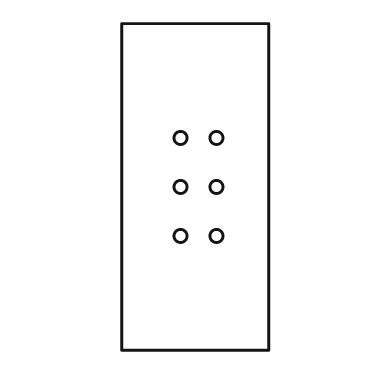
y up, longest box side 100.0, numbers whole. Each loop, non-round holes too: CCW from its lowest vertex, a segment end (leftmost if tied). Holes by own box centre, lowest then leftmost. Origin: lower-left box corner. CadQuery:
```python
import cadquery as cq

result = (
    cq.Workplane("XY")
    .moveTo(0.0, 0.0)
    .lineTo(45.0, 0.0)
    .lineTo(45.0, 100.0)
    .lineTo(0.0, 100.0)
    .close()
    .moveTo(18.0, 35.0)
    .circle(2.0)
    .moveTo(29.0, 35.0)
    .circle(2.0)
    .moveTo(18.0, 50.0)
    .circle(2.0)
    .moveTo(29.0, 50.0)
    .circle(2.0)
    .moveTo(18.0, 65.0)
    .circle(2.0)
    .moveTo(29.0, 65.0)
    .circle(2.0)
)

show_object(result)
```